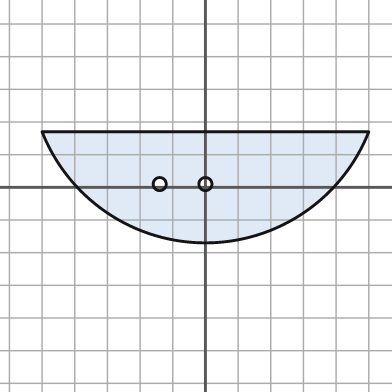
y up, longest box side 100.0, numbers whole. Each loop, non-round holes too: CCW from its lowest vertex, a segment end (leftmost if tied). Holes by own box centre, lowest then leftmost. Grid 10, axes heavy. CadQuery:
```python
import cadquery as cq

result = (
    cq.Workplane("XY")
    .moveTo(-50.0, 17.0)
    .threePointArc((0.0, -17.0), (50.0, 17.0))
    .close()
    .moveTo(-14.0, 1.0)
    .circle(2.0)
    .moveTo(0.0, 1.0)
    .circle(2.0)
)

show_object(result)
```